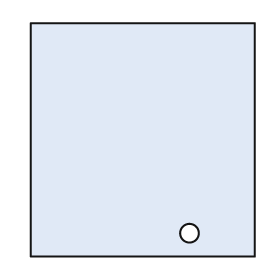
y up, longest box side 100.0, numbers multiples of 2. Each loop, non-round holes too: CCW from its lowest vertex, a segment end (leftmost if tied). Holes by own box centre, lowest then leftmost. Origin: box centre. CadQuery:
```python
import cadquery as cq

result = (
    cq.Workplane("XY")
    .moveTo(-48.0, -50.0)
    .lineTo(48.0, -50.0)
    .lineTo(48.0, 50.0)
    .lineTo(-48.0, 50.0)
    .close()
    .moveTo(20.0, -40.0)
    .circle(4.0)
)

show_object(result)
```